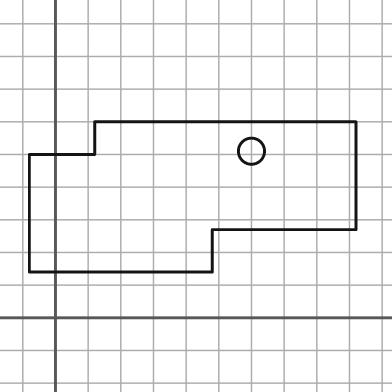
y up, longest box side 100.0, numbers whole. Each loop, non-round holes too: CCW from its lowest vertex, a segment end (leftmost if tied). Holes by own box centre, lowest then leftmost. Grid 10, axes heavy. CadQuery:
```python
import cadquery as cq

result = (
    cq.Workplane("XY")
    .moveTo(-8.0, 14.0)
    .lineTo(48.0, 14.0)
    .lineTo(48.0, 27.0)
    .lineTo(92.0, 27.0)
    .lineTo(92.0, 60.0)
    .lineTo(12.0, 60.0)
    .lineTo(12.0, 50.0)
    .lineTo(-8.0, 50.0)
    .close()
    .moveTo(60.0, 51.0)
    .circle(4.0)
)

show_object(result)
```